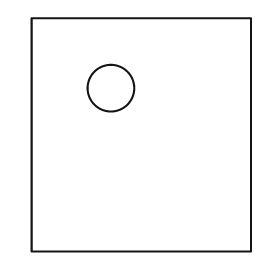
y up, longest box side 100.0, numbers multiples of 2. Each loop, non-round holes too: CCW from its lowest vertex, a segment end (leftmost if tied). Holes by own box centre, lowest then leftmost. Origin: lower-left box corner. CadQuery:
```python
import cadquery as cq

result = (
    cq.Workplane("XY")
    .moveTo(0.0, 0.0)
    .lineTo(94.0, 0.0)
    .lineTo(94.0, 100.0)
    .lineTo(0.0, 100.0)
    .close()
    .moveTo(34.0, 70.0)
    .circle(10.0)
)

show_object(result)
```